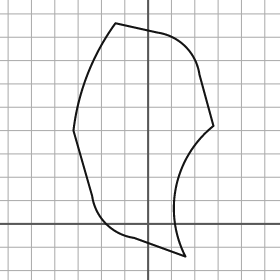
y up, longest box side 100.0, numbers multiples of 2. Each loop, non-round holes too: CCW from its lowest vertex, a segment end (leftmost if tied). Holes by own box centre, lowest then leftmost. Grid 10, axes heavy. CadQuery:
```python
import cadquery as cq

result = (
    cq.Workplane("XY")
    .moveTo(16.0, -14.0)
    .threePointArc((12.0, 16.0), (28.0, 42.0))
    .lineTo(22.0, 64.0)
    .threePointArc((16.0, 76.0), (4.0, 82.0))
    .lineTo(-14.0, 86.0)
    .threePointArc((-26.0, 64.0), (-32.0, 40.0))
    .lineTo(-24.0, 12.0)
    .threePointArc((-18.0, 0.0), (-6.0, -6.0))
    .close()
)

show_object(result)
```